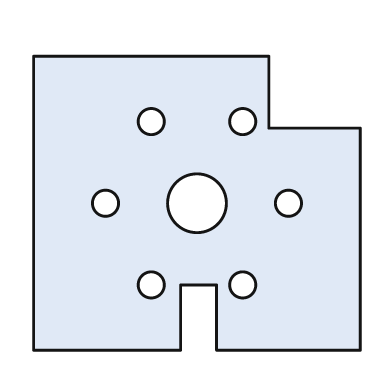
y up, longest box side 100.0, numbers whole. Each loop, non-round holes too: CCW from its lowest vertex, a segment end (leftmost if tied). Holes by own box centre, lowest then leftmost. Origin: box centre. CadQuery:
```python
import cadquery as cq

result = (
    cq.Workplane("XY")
    .moveTo(-50.0, -45.0)
    .lineTo(-5.0, -45.0)
    .lineTo(-5.0, -25.0)
    .lineTo(6.0, -25.0)
    .lineTo(6.0, -45.0)
    .lineTo(50.0, -45.0)
    .lineTo(50.0, 23.0)
    .lineTo(22.0, 23.0)
    .lineTo(22.0, 45.0)
    .lineTo(-50.0, 45.0)
    .close()
    .moveTo(-14.0, -25.0)
    .circle(4.0)
    .moveTo(14.0, -25.0)
    .circle(4.0)
    .moveTo(-28.0, 0.0)
    .circle(4.0)
    .moveTo(0.0, 0.0)
    .circle(9.0)
    .moveTo(28.0, 0.0)
    .circle(4.0)
    .moveTo(-14.0, 25.0)
    .circle(4.0)
    .moveTo(14.0, 25.0)
    .circle(4.0)
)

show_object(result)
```